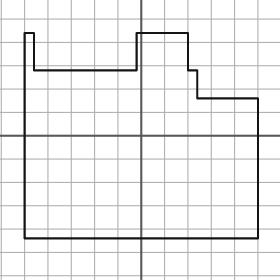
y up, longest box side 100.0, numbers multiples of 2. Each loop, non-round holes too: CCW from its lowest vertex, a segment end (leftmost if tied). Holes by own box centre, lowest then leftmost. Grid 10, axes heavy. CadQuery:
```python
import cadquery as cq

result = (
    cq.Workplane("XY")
    .moveTo(-50.0, -44.0)
    .lineTo(50.0, -44.0)
    .lineTo(50.0, 16.0)
    .lineTo(24.0, 16.0)
    .lineTo(24.0, 28.0)
    .lineTo(20.0, 28.0)
    .lineTo(20.0, 44.0)
    .lineTo(-2.0, 44.0)
    .lineTo(-2.0, 28.0)
    .lineTo(-46.0, 28.0)
    .lineTo(-46.0, 44.0)
    .lineTo(-50.0, 44.0)
    .close()
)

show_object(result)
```